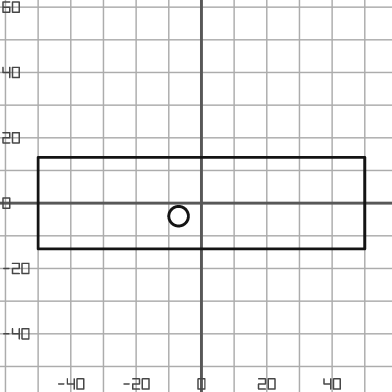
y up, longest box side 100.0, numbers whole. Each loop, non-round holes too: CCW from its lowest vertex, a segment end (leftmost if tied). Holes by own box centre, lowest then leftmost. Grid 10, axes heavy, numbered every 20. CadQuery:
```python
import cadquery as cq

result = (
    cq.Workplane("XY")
    .moveTo(-50.0, -14.0)
    .lineTo(50.0, -14.0)
    .lineTo(50.0, 14.0)
    .lineTo(-50.0, 14.0)
    .close()
    .moveTo(-7.0, -4.0)
    .circle(3.0)
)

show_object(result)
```